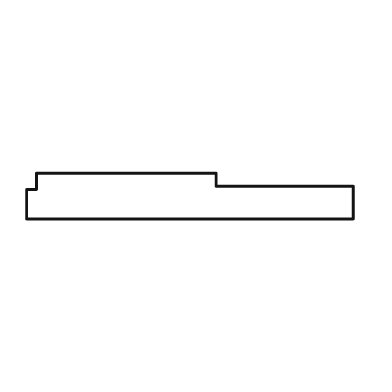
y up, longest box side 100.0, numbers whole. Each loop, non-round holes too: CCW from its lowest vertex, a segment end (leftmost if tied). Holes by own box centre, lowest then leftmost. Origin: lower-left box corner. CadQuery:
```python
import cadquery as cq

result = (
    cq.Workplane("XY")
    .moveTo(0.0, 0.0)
    .lineTo(100.0, 0.0)
    .lineTo(100.0, 10.0)
    .lineTo(58.0, 10.0)
    .lineTo(58.0, 14.0)
    .lineTo(3.0, 14.0)
    .lineTo(3.0, 9.0)
    .lineTo(0.0, 9.0)
    .close()
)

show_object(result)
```